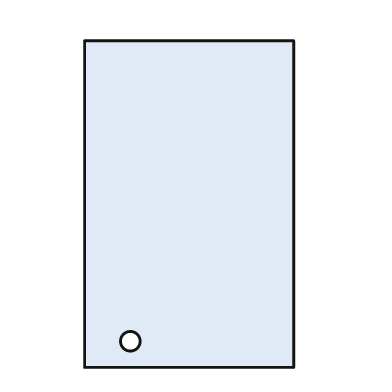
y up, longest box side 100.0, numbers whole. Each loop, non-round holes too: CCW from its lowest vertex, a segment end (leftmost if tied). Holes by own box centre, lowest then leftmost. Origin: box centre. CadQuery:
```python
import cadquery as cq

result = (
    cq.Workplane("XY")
    .moveTo(-32.0, -50.0)
    .lineTo(32.0, -50.0)
    .lineTo(32.0, 50.0)
    .lineTo(-32.0, 50.0)
    .close()
    .moveTo(-18.0, -42.0)
    .circle(3.0)
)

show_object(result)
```